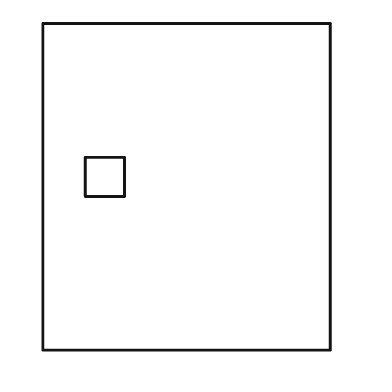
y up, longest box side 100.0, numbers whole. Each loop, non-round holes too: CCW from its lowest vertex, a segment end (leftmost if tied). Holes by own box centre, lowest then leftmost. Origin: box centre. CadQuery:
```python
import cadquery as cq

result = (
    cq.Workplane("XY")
    .moveTo(-44.0, -50.0)
    .lineTo(44.0, -50.0)
    .lineTo(44.0, 50.0)
    .lineTo(-44.0, 50.0)
    .close()
    .moveTo(-31.0, -3.0)
    .lineTo(-19.0, -3.0)
    .lineTo(-19.0, 9.0)
    .lineTo(-31.0, 9.0)
    .close()
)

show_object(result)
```